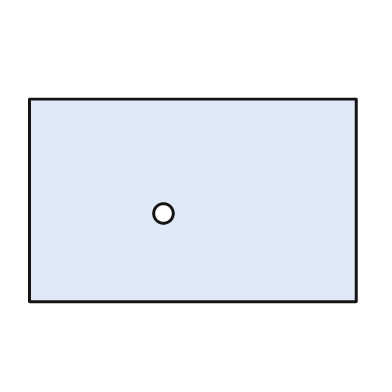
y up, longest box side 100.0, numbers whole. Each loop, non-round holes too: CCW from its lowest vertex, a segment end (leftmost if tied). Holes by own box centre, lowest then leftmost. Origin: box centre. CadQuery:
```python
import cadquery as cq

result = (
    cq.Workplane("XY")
    .moveTo(-50.0, -31.0)
    .lineTo(50.0, -31.0)
    .lineTo(50.0, 31.0)
    .lineTo(-50.0, 31.0)
    .close()
    .moveTo(-9.0, -4.0)
    .circle(3.0)
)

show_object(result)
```